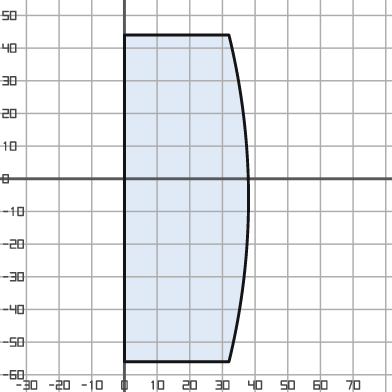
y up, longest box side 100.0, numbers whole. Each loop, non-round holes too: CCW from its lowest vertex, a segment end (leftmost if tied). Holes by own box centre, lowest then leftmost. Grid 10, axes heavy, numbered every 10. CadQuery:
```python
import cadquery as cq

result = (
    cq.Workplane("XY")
    .moveTo(0.0, -56.0)
    .lineTo(32.0, -56.0)
    .threePointArc((38.0, -6.0), (32.0, 44.0))
    .lineTo(0.0, 44.0)
    .close()
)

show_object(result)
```